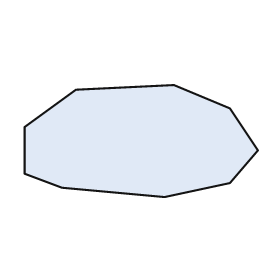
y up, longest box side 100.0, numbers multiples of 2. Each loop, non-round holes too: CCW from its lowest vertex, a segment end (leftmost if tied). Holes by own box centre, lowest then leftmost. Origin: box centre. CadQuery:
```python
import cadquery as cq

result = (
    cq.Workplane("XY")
    .moveTo(10.0, -24.0)
    .lineTo(38.0, -18.0)
    .lineTo(50.0, -4.0)
    .lineTo(38.0, 14.0)
    .lineTo(14.0, 24.0)
    .lineTo(-28.0, 22.0)
    .lineTo(-50.0, 6.0)
    .lineTo(-50.0, -14.0)
    .lineTo(-34.0, -20.0)
    .close()
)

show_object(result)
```